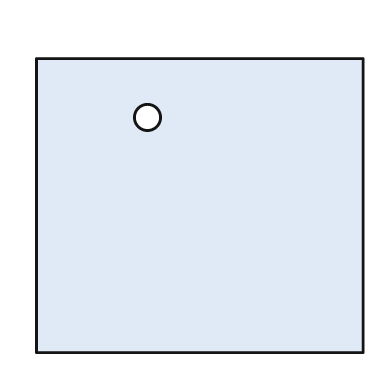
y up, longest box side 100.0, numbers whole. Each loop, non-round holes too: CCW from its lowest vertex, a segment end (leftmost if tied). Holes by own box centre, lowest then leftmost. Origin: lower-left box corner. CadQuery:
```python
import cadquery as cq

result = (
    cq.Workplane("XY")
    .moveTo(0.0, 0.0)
    .lineTo(100.0, 0.0)
    .lineTo(100.0, 90.0)
    .lineTo(0.0, 90.0)
    .close()
    .moveTo(34.0, 72.0)
    .circle(4.0)
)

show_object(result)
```